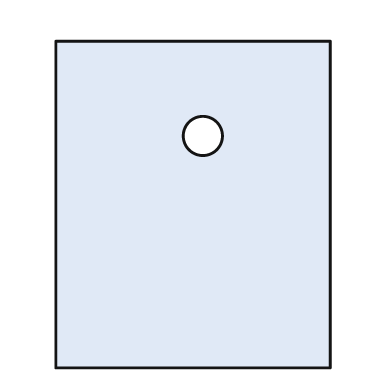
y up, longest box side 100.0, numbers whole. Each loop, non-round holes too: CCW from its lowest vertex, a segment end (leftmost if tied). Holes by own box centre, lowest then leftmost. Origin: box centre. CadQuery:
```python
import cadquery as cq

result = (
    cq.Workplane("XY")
    .moveTo(-42.0, -50.0)
    .lineTo(42.0, -50.0)
    .lineTo(42.0, 50.0)
    .lineTo(-42.0, 50.0)
    .close()
    .moveTo(3.0, 21.0)
    .circle(6.0)
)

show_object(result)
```